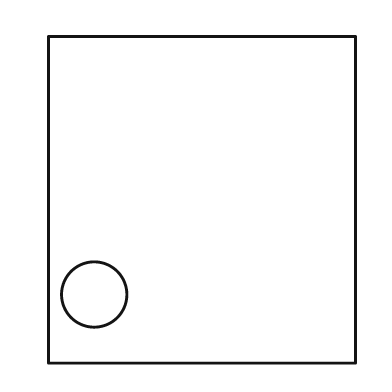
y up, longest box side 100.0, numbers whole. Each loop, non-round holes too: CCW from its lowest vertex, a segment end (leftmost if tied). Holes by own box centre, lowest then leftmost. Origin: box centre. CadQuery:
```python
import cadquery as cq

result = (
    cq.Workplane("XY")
    .moveTo(-47.0, -50.0)
    .lineTo(47.0, -50.0)
    .lineTo(47.0, 50.0)
    .lineTo(-47.0, 50.0)
    .close()
    .moveTo(-33.0, -29.0)
    .circle(10.0)
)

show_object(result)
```